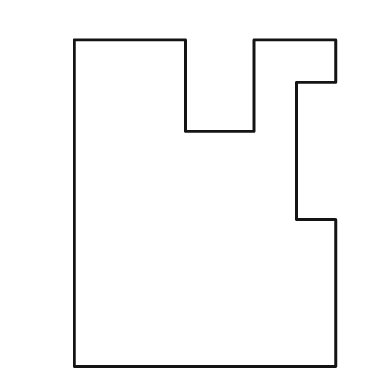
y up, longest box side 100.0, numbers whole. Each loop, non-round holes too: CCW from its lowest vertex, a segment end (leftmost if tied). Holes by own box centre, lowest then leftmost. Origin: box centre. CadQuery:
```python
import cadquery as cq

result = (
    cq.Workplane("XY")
    .moveTo(-40.0, -50.0)
    .lineTo(40.0, -50.0)
    .lineTo(40.0, -5.0)
    .lineTo(28.0, -5.0)
    .lineTo(28.0, 37.0)
    .lineTo(40.0, 37.0)
    .lineTo(40.0, 50.0)
    .lineTo(15.0, 50.0)
    .lineTo(15.0, 22.0)
    .lineTo(-6.0, 22.0)
    .lineTo(-6.0, 50.0)
    .lineTo(-40.0, 50.0)
    .close()
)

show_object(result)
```